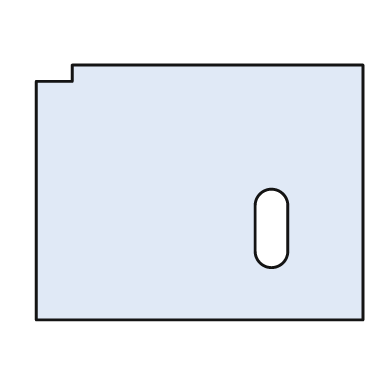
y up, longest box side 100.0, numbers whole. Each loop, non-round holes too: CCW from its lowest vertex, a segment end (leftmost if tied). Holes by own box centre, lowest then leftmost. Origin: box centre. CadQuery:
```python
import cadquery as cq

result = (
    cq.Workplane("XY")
    .moveTo(-50.0, -39.0)
    .lineTo(50.0, -39.0)
    .lineTo(50.0, 39.0)
    .lineTo(-39.0, 39.0)
    .lineTo(-39.0, 34.0)
    .lineTo(-50.0, 34.0)
    .close()
    .moveTo(17.0, -18.0)
    .threePointArc((22.0, -23.0), (27.0, -18.0))
    .lineTo(27.0, -4.0)
    .threePointArc((22.0, 1.0), (17.0, -4.0))
    .close()
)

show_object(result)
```